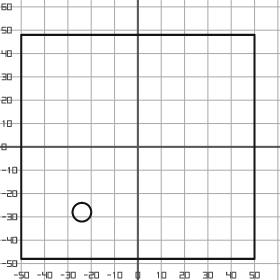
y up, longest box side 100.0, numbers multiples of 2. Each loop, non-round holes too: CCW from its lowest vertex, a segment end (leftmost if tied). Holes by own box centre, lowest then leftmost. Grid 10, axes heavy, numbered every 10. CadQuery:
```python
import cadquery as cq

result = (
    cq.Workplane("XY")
    .moveTo(-50.0, -48.0)
    .lineTo(50.0, -48.0)
    .lineTo(50.0, 48.0)
    .lineTo(-50.0, 48.0)
    .close()
    .moveTo(-24.0, -28.0)
    .circle(4.0)
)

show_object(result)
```